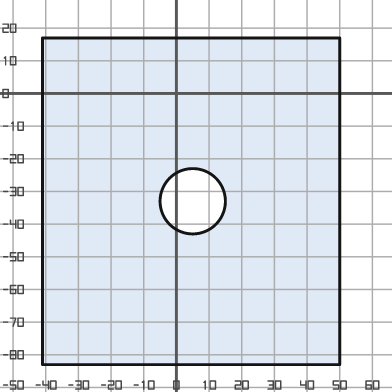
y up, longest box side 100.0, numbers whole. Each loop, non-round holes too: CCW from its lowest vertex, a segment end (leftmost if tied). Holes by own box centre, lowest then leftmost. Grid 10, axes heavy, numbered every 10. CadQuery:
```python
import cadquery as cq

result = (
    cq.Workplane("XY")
    .moveTo(-41.0, -83.0)
    .lineTo(50.0, -83.0)
    .lineTo(50.0, 17.0)
    .lineTo(-41.0, 17.0)
    .close()
    .moveTo(5.0, -33.0)
    .circle(10.0)
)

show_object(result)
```